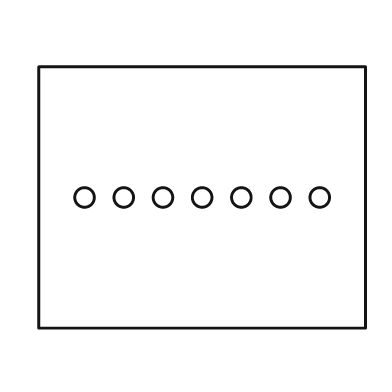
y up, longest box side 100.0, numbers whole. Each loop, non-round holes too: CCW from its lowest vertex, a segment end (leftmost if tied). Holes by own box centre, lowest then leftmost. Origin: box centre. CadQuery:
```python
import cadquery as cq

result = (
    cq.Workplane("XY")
    .moveTo(-50.0, -40.0)
    .lineTo(50.0, -40.0)
    .lineTo(50.0, 40.0)
    .lineTo(-50.0, 40.0)
    .close()
    .moveTo(-36.0, 0.0)
    .circle(3.0)
    .moveTo(-24.0, 0.0)
    .circle(3.0)
    .moveTo(-12.0, 0.0)
    .circle(3.0)
    .moveTo(0.0, 0.0)
    .circle(3.0)
    .moveTo(12.0, 0.0)
    .circle(3.0)
    .moveTo(24.0, 0.0)
    .circle(3.0)
    .moveTo(36.0, 0.0)
    .circle(3.0)
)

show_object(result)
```